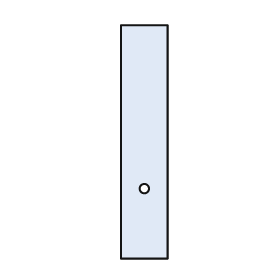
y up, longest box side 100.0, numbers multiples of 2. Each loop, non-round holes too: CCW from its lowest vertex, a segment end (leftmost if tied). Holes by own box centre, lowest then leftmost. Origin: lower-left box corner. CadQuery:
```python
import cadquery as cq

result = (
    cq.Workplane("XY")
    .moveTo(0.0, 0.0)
    .lineTo(20.0, 0.0)
    .lineTo(20.0, 100.0)
    .lineTo(0.0, 100.0)
    .close()
    .moveTo(10.0, 30.0)
    .circle(2.0)
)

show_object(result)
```